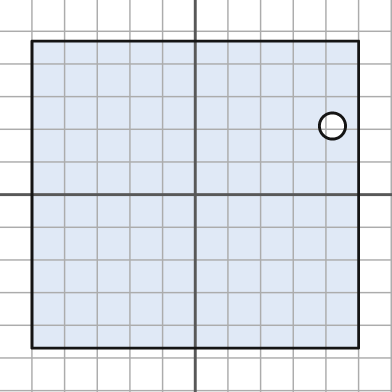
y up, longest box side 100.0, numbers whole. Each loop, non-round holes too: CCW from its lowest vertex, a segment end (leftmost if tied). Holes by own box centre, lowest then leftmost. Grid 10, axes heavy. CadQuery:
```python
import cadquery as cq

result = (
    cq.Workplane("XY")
    .moveTo(-50.0, -47.0)
    .lineTo(50.0, -47.0)
    .lineTo(50.0, 47.0)
    .lineTo(-50.0, 47.0)
    .close()
    .moveTo(42.0, 21.0)
    .circle(4.0)
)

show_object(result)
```